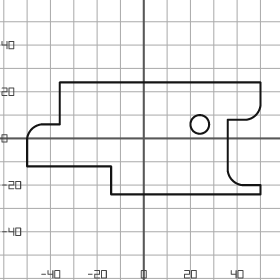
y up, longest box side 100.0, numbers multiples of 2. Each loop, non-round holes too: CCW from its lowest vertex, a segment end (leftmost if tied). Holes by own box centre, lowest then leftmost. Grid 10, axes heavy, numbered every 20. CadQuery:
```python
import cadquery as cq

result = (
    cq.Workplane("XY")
    .moveTo(-14.0, -24.0)
    .lineTo(50.0, -24.0)
    .lineTo(50.0, -20.0)
    .lineTo(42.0, -20.0)
    .threePointArc((38.0, -18.0), (36.0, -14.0))
    .lineTo(36.0, 8.0)
    .lineTo(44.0, 8.0)
    .threePointArc((48.0, 10.0), (50.0, 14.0))
    .lineTo(50.0, 24.0)
    .lineTo(-36.0, 24.0)
    .lineTo(-36.0, 6.0)
    .lineTo(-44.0, 6.0)
    .threePointArc((-48.0, 4.0), (-50.0, 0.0))
    .lineTo(-50.0, -12.0)
    .lineTo(-14.0, -12.0)
    .close()
    .moveTo(24.0, 6.0)
    .circle(4.0)
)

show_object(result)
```